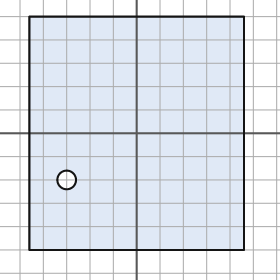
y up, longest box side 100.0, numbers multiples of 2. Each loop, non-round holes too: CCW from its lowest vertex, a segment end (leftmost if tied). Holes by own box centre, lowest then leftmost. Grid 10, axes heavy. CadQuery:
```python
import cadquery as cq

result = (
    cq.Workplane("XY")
    .moveTo(-46.0, -50.0)
    .lineTo(46.0, -50.0)
    .lineTo(46.0, 50.0)
    .lineTo(-46.0, 50.0)
    .close()
    .moveTo(-30.0, -20.0)
    .circle(4.0)
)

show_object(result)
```